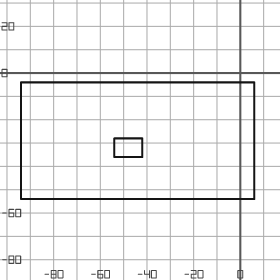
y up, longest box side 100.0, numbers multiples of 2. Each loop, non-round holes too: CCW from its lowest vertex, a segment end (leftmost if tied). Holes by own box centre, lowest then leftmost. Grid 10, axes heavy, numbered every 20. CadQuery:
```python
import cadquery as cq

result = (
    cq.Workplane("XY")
    .moveTo(-94.0, -54.0)
    .lineTo(6.0, -54.0)
    .lineTo(6.0, -4.0)
    .lineTo(-94.0, -4.0)
    .close()
    .moveTo(-54.0, -36.0)
    .lineTo(-42.0, -36.0)
    .lineTo(-42.0, -28.0)
    .lineTo(-54.0, -28.0)
    .close()
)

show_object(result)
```